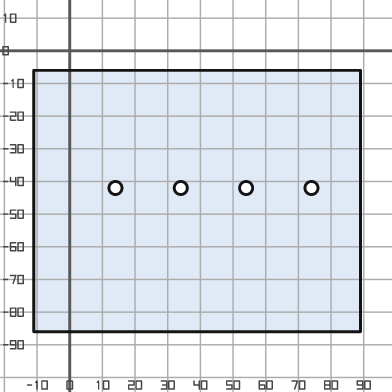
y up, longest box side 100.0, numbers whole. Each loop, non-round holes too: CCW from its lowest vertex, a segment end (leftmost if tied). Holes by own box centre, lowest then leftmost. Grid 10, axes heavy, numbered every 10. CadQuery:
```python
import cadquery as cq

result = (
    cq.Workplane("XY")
    .moveTo(-11.0, -86.0)
    .lineTo(89.0, -86.0)
    .lineTo(89.0, -6.0)
    .lineTo(-11.0, -6.0)
    .close()
    .moveTo(14.0, -42.0)
    .circle(2.0)
    .moveTo(34.0, -42.0)
    .circle(2.0)
    .moveTo(54.0, -42.0)
    .circle(2.0)
    .moveTo(74.0, -42.0)
    .circle(2.0)
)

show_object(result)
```